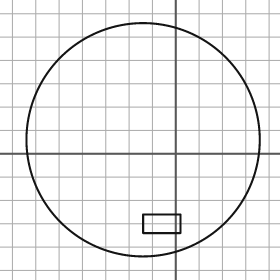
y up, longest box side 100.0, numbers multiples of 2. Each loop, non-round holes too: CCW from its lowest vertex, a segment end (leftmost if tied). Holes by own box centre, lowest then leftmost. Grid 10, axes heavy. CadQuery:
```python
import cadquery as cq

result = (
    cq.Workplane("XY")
    .moveTo(-14.0, 6.0)
    .circle(50.0)
    .moveTo(-14.0, -34.0)
    .lineTo(2.0, -34.0)
    .lineTo(2.0, -26.0)
    .lineTo(-14.0, -26.0)
    .close()
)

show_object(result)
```